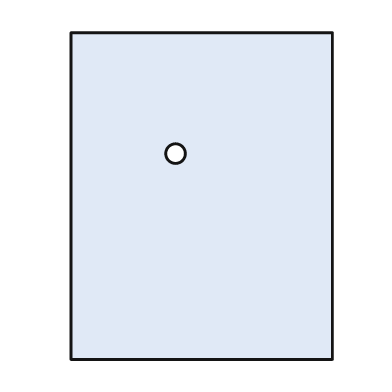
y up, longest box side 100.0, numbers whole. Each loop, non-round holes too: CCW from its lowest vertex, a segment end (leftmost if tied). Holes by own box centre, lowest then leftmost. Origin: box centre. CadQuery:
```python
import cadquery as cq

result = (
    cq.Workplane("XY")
    .moveTo(-40.0, -50.0)
    .lineTo(40.0, -50.0)
    .lineTo(40.0, 50.0)
    .lineTo(-40.0, 50.0)
    .close()
    .moveTo(-8.0, 13.0)
    .circle(3.0)
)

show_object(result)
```